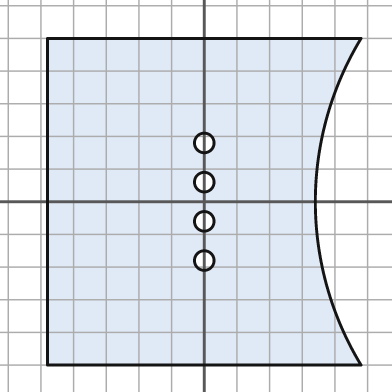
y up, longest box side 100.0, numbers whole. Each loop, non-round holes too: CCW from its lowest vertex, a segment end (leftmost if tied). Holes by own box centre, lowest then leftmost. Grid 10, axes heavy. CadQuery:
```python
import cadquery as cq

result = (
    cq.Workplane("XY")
    .moveTo(-48.0, -50.0)
    .lineTo(48.0, -50.0)
    .threePointArc((34.0, 0.0), (48.0, 50.0))
    .lineTo(-48.0, 50.0)
    .close()
    .moveTo(0.0, -18.0)
    .circle(3.0)
    .moveTo(0.0, -6.0)
    .circle(3.0)
    .moveTo(0.0, 6.0)
    .circle(3.0)
    .moveTo(0.0, 18.0)
    .circle(3.0)
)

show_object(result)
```